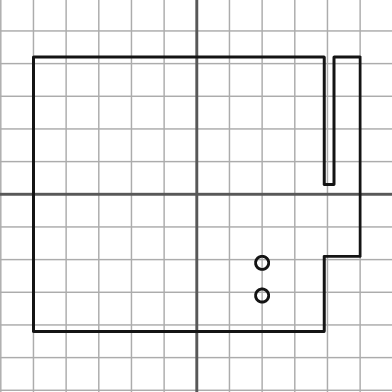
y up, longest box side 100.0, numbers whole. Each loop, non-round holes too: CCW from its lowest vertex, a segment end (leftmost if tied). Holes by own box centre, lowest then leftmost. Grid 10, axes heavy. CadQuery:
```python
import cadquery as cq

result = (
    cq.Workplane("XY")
    .moveTo(-50.0, -42.0)
    .lineTo(39.0, -42.0)
    .lineTo(39.0, -19.0)
    .lineTo(50.0, -19.0)
    .lineTo(50.0, 42.0)
    .lineTo(42.0, 42.0)
    .lineTo(42.0, 3.0)
    .lineTo(39.0, 3.0)
    .lineTo(39.0, 42.0)
    .lineTo(-50.0, 42.0)
    .close()
    .moveTo(20.0, -31.0)
    .circle(2.0)
    .moveTo(20.0, -21.0)
    .circle(2.0)
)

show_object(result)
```